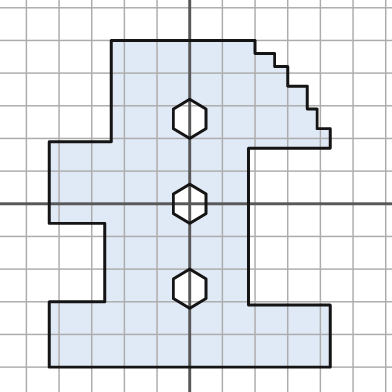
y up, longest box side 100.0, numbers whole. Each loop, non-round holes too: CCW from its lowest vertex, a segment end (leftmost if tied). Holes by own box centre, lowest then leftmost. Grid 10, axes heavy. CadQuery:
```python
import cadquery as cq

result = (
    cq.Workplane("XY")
    .moveTo(-43.0, -50.0)
    .lineTo(43.0, -50.0)
    .lineTo(43.0, -31.0)
    .lineTo(18.0, -31.0)
    .lineTo(18.0, 17.0)
    .lineTo(43.0, 17.0)
    .lineTo(43.0, 23.0)
    .lineTo(39.0, 23.0)
    .lineTo(39.0, 29.0)
    .lineTo(36.0, 29.0)
    .lineTo(36.0, 36.0)
    .lineTo(30.0, 36.0)
    .lineTo(30.0, 42.0)
    .lineTo(26.0, 42.0)
    .lineTo(26.0, 46.0)
    .lineTo(20.0, 46.0)
    .lineTo(20.0, 50.0)
    .lineTo(-24.0, 50.0)
    .lineTo(-24.0, 19.0)
    .lineTo(-43.0, 19.0)
    .lineTo(-43.0, -6.0)
    .lineTo(-26.0, -6.0)
    .lineTo(-26.0, -30.0)
    .lineTo(-43.0, -30.0)
    .close()
    .moveTo(0.0, -32.0)
    .lineTo(5.0, -29.0)
    .lineTo(5.0, -23.0)
    .lineTo(0.0, -20.0)
    .lineTo(-5.0, -23.0)
    .lineTo(-5.0, -29.0)
    .close()
    .moveTo(0.0, -6.0)
    .lineTo(5.0, -3.0)
    .lineTo(5.0, 3.0)
    .lineTo(0.0, 6.0)
    .lineTo(-5.0, 3.0)
    .lineTo(-5.0, -3.0)
    .close()
    .moveTo(0.0, 20.0)
    .lineTo(5.0, 23.0)
    .lineTo(5.0, 29.0)
    .lineTo(0.0, 32.0)
    .lineTo(-5.0, 29.0)
    .lineTo(-5.0, 23.0)
    .close()
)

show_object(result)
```